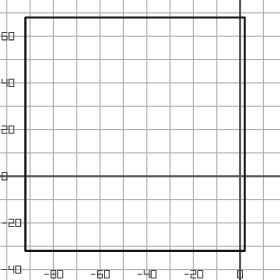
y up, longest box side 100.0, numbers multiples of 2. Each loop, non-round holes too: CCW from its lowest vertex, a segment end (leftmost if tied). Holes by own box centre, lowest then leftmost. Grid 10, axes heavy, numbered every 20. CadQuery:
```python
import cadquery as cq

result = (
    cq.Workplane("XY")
    .moveTo(-92.0, -32.0)
    .lineTo(2.0, -32.0)
    .lineTo(2.0, 68.0)
    .lineTo(-92.0, 68.0)
    .close()
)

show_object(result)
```